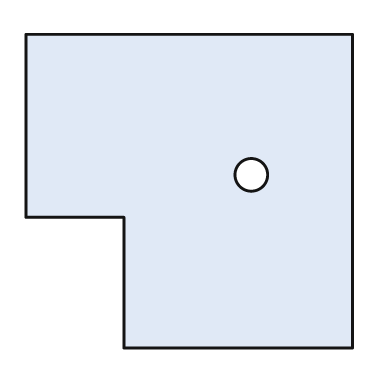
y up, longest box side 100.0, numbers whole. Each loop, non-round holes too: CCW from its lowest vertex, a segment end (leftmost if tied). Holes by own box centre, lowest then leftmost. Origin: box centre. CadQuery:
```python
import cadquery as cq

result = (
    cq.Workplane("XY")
    .moveTo(-20.0, -48.0)
    .lineTo(50.0, -48.0)
    .lineTo(50.0, 48.0)
    .lineTo(-50.0, 48.0)
    .lineTo(-50.0, -8.0)
    .lineTo(-20.0, -8.0)
    .close()
    .moveTo(19.0, 5.0)
    .circle(5.0)
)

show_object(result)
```